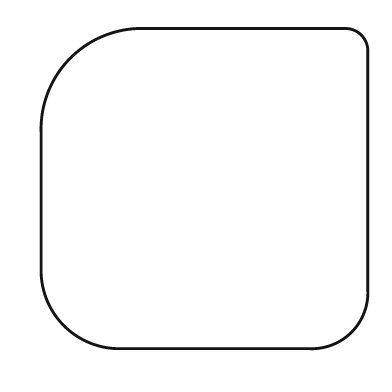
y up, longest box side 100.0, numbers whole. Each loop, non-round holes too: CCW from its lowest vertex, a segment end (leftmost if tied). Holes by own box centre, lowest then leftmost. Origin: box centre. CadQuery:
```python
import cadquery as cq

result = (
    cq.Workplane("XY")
    .moveTo(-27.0, -49.0)
    .lineTo(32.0, -49.0)
    .threePointArc((45.0, -44.0), (50.0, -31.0))
    .lineTo(50.0, 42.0)
    .threePointArc((48.0, 47.0), (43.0, 49.0))
    .lineTo(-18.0, 49.0)
    .threePointArc((-41.0, 40.0), (-50.0, 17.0))
    .lineTo(-50.0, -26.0)
    .threePointArc((-43.0, -42.0), (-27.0, -49.0))
    .close()
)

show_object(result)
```